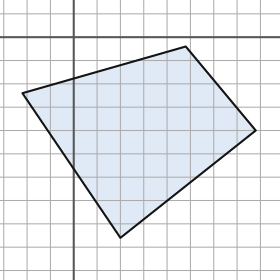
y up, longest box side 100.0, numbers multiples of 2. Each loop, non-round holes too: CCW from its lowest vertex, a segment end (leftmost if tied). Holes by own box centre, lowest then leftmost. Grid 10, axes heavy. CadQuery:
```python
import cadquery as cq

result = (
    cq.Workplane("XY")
    .moveTo(20.0, -86.0)
    .lineTo(78.0, -40.0)
    .lineTo(48.0, -4.0)
    .lineTo(-22.0, -24.0)
    .close()
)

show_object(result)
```